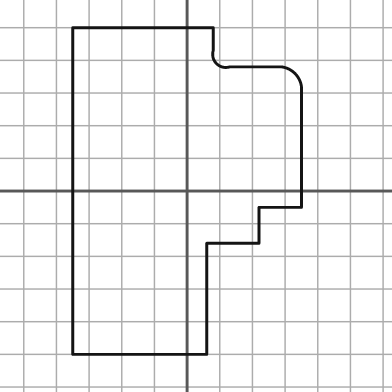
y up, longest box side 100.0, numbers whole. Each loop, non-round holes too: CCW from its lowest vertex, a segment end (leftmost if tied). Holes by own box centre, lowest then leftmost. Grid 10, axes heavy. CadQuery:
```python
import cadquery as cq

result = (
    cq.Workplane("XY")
    .moveTo(-35.0, -50.0)
    .lineTo(6.0, -50.0)
    .lineTo(6.0, -16.0)
    .lineTo(22.0, -16.0)
    .lineTo(22.0, -5.0)
    .lineTo(35.0, -5.0)
    .lineTo(35.0, 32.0)
    .threePointArc((33.0, 36.0), (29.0, 38.0))
    .lineTo(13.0, 38.0)
    .threePointArc((9.0, 39.0), (8.0, 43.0))
    .lineTo(8.0, 50.0)
    .lineTo(-35.0, 50.0)
    .close()
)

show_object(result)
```